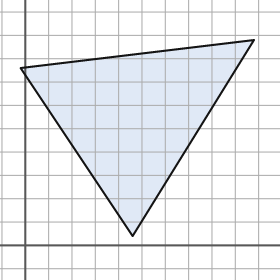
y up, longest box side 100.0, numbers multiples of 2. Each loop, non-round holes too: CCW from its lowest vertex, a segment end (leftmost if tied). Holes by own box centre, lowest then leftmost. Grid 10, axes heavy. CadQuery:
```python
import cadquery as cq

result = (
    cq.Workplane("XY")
    .moveTo(46.0, 4.0)
    .lineTo(98.0, 88.0)
    .lineTo(-2.0, 76.0)
    .close()
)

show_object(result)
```